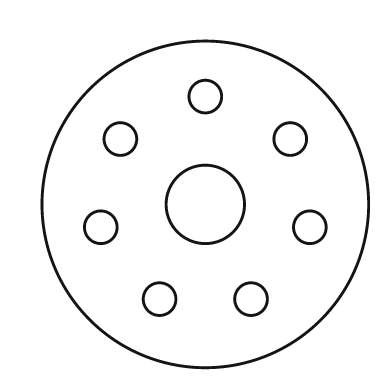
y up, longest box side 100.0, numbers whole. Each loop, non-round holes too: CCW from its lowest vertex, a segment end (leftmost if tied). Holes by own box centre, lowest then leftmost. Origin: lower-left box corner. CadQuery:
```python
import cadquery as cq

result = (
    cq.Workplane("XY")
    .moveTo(50.0, 50.0)
    .circle(50.0)
    .moveTo(36.0, 21.0)
    .circle(5.0)
    .moveTo(64.0, 21.0)
    .circle(5.0)
    .moveTo(18.0, 43.0)
    .circle(5.0)
    .moveTo(82.0, 43.0)
    .circle(5.0)
    .moveTo(50.0, 50.0)
    .circle(12.0)
    .moveTo(24.0, 70.0)
    .circle(5.0)
    .moveTo(76.0, 70.0)
    .circle(5.0)
    .moveTo(50.0, 83.0)
    .circle(5.0)
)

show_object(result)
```